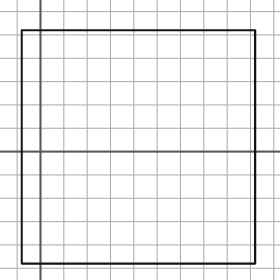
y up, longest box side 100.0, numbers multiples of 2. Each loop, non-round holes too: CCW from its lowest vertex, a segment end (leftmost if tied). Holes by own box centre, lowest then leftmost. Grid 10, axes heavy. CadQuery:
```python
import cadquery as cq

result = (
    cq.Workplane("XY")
    .moveTo(-8.0, -48.0)
    .lineTo(92.0, -48.0)
    .lineTo(92.0, 52.0)
    .lineTo(-8.0, 52.0)
    .close()
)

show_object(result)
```